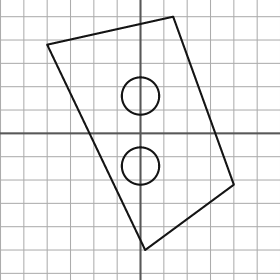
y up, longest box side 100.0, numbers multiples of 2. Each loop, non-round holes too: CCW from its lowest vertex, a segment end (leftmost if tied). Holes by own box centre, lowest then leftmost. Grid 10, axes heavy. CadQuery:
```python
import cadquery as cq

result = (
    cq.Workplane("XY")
    .moveTo(2.0, -50.0)
    .lineTo(40.0, -22.0)
    .lineTo(14.0, 50.0)
    .lineTo(-40.0, 38.0)
    .close()
    .moveTo(0.0, -14.0)
    .circle(8.0)
    .moveTo(0.0, 16.0)
    .circle(8.0)
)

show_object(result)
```